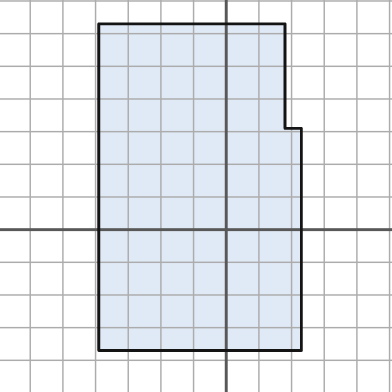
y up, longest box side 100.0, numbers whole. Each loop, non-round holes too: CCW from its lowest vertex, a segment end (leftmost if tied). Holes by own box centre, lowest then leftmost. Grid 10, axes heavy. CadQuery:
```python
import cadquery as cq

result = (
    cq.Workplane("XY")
    .moveTo(-39.0, -37.0)
    .lineTo(23.0, -37.0)
    .lineTo(23.0, 31.0)
    .lineTo(18.0, 31.0)
    .lineTo(18.0, 63.0)
    .lineTo(-39.0, 63.0)
    .close()
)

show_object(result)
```